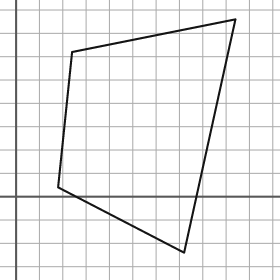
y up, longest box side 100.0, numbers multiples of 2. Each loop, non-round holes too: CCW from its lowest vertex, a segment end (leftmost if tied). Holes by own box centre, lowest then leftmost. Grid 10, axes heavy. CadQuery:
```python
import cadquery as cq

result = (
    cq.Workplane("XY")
    .moveTo(72.0, -24.0)
    .lineTo(94.0, 76.0)
    .lineTo(24.0, 62.0)
    .lineTo(18.0, 4.0)
    .close()
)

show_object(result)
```